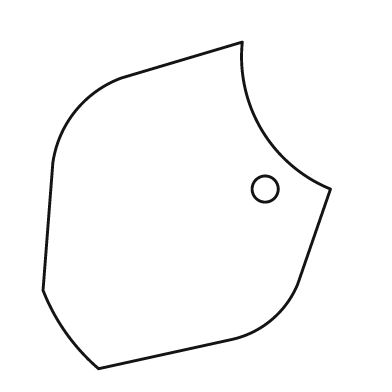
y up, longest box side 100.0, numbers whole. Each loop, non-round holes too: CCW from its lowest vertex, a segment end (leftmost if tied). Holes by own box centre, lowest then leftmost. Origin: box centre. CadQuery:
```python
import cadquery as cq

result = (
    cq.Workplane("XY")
    .moveTo(-27.0, -50.0)
    .lineTo(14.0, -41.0)
    .threePointArc((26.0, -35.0), (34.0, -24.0))
    .lineTo(44.0, 5.0)
    .threePointArc((23.0, 23.0), (17.0, 50.0))
    .lineTo(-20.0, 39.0)
    .threePointArc((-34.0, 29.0), (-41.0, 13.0))
    .lineTo(-44.0, -26.0)
    .threePointArc((-37.0, -39.0), (-27.0, -50.0))
    .close()
    .moveTo(24.0, 5.0)
    .circle(4.0)
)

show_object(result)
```